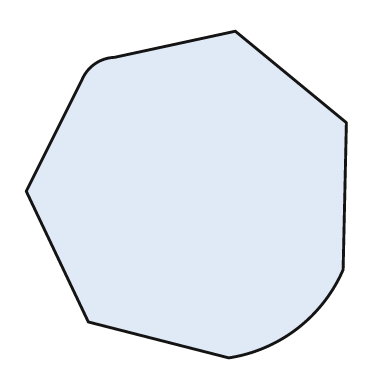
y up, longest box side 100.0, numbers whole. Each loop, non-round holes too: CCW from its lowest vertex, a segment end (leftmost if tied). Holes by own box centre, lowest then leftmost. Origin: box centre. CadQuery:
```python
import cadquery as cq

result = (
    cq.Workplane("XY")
    .moveTo(13.0, -50.0)
    .threePointArc((34.0, -41.0), (48.0, -23.0))
    .lineTo(49.0, 22.0)
    .lineTo(15.0, 50.0)
    .lineTo(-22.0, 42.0)
    .threePointArc((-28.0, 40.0), (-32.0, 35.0))
    .lineTo(-49.0, 1.0)
    .lineTo(-30.0, -39.0)
    .close()
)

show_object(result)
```